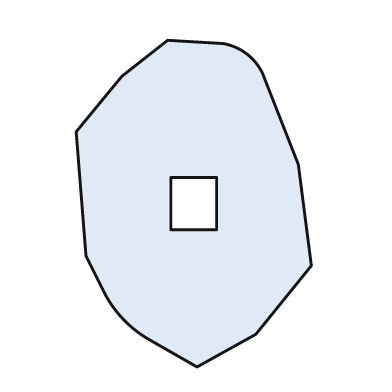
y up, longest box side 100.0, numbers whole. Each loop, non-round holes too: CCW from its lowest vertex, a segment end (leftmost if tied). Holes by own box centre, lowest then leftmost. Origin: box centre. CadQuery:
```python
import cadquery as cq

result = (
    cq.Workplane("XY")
    .moveTo(1.0, -50.0)
    .lineTo(19.0, -40.0)
    .lineTo(36.0, -19.0)
    .lineTo(32.0, 12.0)
    .lineTo(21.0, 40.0)
    .threePointArc((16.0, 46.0), (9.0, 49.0))
    .lineTo(-8.0, 50.0)
    .lineTo(-22.0, 39.0)
    .lineTo(-36.0, 22.0)
    .lineTo(-33.0, -16.0)
    .lineTo(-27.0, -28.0)
    .threePointArc((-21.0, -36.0), (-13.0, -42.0))
    .close()
    .moveTo(-7.0, -8.0)
    .lineTo(7.0, -8.0)
    .lineTo(7.0, 8.0)
    .lineTo(-7.0, 8.0)
    .close()
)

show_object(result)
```